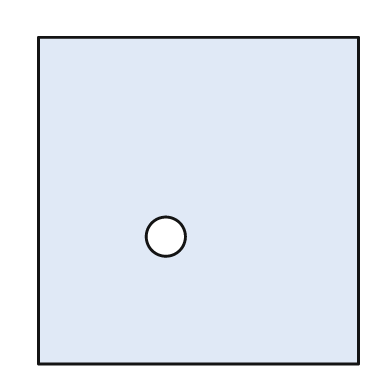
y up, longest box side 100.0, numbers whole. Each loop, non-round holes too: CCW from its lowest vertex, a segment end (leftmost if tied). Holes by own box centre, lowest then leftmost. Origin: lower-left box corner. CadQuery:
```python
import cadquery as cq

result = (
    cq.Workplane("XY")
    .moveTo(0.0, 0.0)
    .lineTo(98.0, 0.0)
    .lineTo(98.0, 100.0)
    .lineTo(0.0, 100.0)
    .close()
    .moveTo(39.0, 39.0)
    .circle(6.0)
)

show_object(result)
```